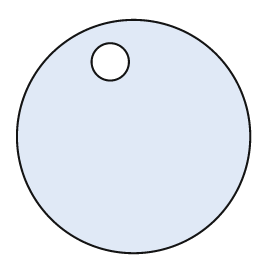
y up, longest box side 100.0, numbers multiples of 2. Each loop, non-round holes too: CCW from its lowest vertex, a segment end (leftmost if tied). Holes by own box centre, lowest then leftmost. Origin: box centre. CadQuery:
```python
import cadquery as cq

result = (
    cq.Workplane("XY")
    .moveTo(0.0, 0.0)
    .circle(50.0)
    .moveTo(-10.0, 32.0)
    .circle(8.0)
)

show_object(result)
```